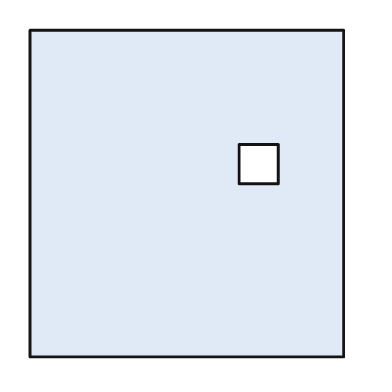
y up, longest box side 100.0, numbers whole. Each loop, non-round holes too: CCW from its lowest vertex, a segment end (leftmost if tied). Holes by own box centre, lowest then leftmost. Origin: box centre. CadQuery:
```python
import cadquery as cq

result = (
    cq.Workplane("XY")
    .moveTo(-48.0, -50.0)
    .lineTo(48.0, -50.0)
    .lineTo(48.0, 50.0)
    .lineTo(-48.0, 50.0)
    .close()
    .moveTo(16.0, 3.0)
    .lineTo(28.0, 3.0)
    .lineTo(28.0, 15.0)
    .lineTo(16.0, 15.0)
    .close()
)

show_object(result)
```